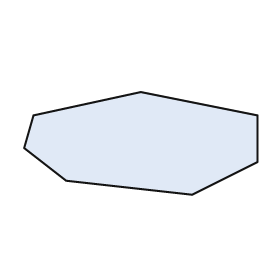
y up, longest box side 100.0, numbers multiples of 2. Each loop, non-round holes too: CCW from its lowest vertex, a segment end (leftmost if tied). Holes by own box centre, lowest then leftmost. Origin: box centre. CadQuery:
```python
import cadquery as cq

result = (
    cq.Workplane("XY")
    .moveTo(22.0, -22.0)
    .lineTo(50.0, -8.0)
    .lineTo(50.0, 12.0)
    .lineTo(0.0, 22.0)
    .lineTo(-46.0, 12.0)
    .lineTo(-50.0, -2.0)
    .lineTo(-32.0, -16.0)
    .close()
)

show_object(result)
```